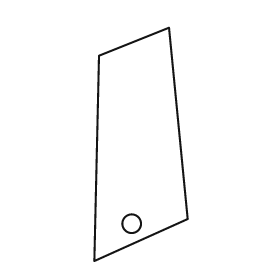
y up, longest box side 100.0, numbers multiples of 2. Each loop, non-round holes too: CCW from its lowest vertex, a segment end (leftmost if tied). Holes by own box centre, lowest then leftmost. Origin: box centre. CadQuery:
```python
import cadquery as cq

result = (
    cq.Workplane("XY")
    .moveTo(-20.0, -50.0)
    .lineTo(20.0, -32.0)
    .lineTo(12.0, 50.0)
    .lineTo(-18.0, 38.0)
    .close()
    .moveTo(-4.0, -34.0)
    .circle(4.0)
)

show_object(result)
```